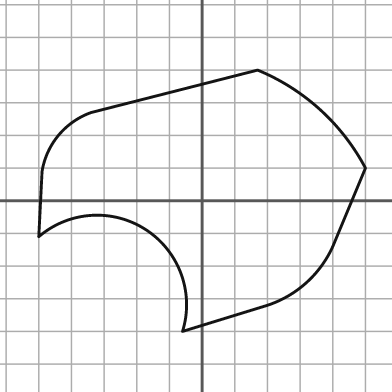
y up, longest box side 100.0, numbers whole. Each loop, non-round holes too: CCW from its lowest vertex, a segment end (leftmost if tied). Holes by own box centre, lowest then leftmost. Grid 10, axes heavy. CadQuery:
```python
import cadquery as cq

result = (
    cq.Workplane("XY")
    .moveTo(-6.0, -40.0)
    .lineTo(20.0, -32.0)
    .threePointArc((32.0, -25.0), (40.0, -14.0))
    .lineTo(50.0, 10.0)
    .threePointArc((36.0, 28.0), (17.0, 40.0))
    .lineTo(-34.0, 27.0)
    .threePointArc((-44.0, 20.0), (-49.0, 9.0))
    .lineTo(-50.0, -11.0)
    .threePointArc((-17.0, -9.0), (-6.0, -40.0))
    .close()
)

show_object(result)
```